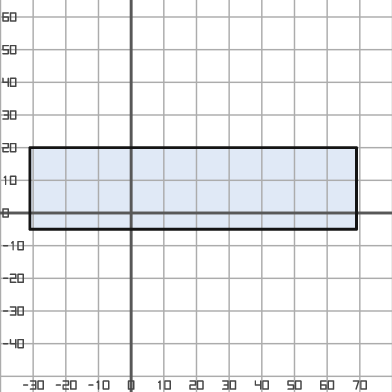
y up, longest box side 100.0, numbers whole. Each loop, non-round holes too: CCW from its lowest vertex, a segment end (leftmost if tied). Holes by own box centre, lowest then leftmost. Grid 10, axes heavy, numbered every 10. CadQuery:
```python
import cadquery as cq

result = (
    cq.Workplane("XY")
    .moveTo(-31.0, -5.0)
    .lineTo(69.0, -5.0)
    .lineTo(69.0, 20.0)
    .lineTo(-31.0, 20.0)
    .close()
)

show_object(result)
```